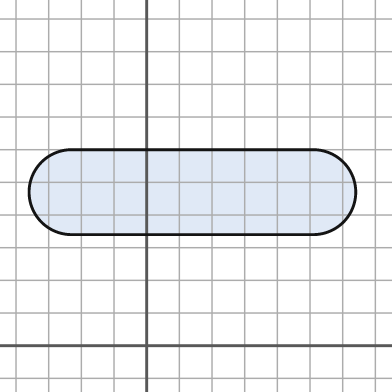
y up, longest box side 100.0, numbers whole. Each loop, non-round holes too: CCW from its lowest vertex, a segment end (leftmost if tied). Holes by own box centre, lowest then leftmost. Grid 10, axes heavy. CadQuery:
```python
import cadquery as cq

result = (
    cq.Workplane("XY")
    .moveTo(-23.0, 34.0)
    .lineTo(51.0, 34.0)
    .threePointArc((64.0, 47.0), (51.0, 60.0))
    .lineTo(-23.0, 60.0)
    .threePointArc((-36.0, 47.0), (-23.0, 34.0))
    .close()
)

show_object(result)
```